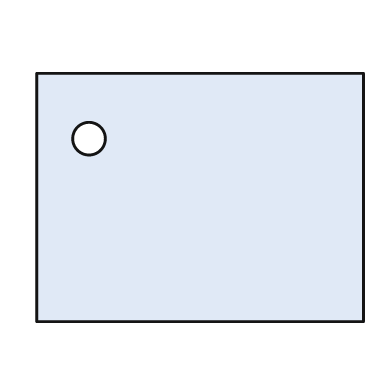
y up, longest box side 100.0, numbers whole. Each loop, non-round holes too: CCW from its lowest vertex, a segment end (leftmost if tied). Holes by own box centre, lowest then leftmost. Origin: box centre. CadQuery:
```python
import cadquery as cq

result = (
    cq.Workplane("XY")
    .moveTo(-50.0, -38.0)
    .lineTo(50.0, -38.0)
    .lineTo(50.0, 38.0)
    .lineTo(-50.0, 38.0)
    .close()
    .moveTo(-34.0, 18.0)
    .circle(5.0)
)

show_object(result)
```